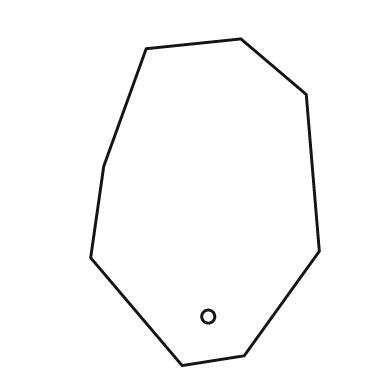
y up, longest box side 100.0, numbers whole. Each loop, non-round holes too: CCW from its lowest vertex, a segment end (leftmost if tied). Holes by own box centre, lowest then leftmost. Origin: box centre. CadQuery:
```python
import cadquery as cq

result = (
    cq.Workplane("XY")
    .moveTo(-7.0, -50.0)
    .lineTo(12.0, -47.0)
    .lineTo(35.0, -15.0)
    .lineTo(31.0, 33.0)
    .lineTo(11.0, 50.0)
    .lineTo(-18.0, 47.0)
    .lineTo(-31.0, 11.0)
    .lineTo(-35.0, -17.0)
    .close()
    .moveTo(1.0, -35.0)
    .circle(2.0)
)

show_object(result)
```